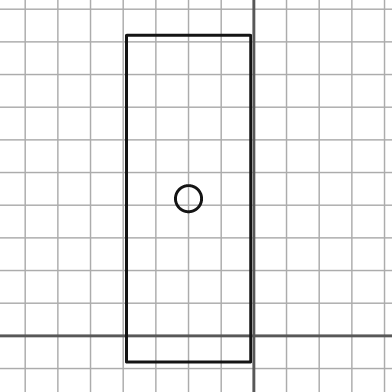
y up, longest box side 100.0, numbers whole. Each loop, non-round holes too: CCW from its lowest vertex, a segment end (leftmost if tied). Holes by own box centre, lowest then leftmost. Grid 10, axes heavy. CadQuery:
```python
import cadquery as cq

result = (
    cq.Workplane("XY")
    .moveTo(-39.0, -8.0)
    .lineTo(-1.0, -8.0)
    .lineTo(-1.0, 92.0)
    .lineTo(-39.0, 92.0)
    .close()
    .moveTo(-20.0, 42.0)
    .circle(4.0)
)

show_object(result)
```